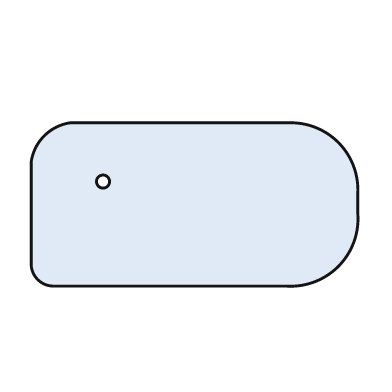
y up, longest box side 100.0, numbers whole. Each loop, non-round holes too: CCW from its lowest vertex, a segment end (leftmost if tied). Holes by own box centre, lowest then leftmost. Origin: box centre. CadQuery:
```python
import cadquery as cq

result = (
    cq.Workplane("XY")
    .moveTo(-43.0, -25.0)
    .lineTo(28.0, -25.0)
    .threePointArc((44.0, -19.0), (50.0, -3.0))
    .lineTo(50.0, 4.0)
    .threePointArc((44.0, 19.0), (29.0, 25.0))
    .lineTo(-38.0, 25.0)
    .threePointArc((-46.0, 21.0), (-50.0, 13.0))
    .lineTo(-50.0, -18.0)
    .threePointArc((-48.0, -23.0), (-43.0, -25.0))
    .close()
    .moveTo(-28.0, 7.0)
    .circle(2.0)
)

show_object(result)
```